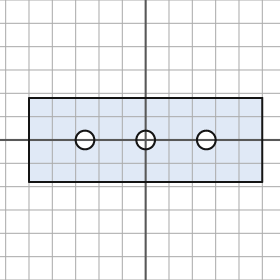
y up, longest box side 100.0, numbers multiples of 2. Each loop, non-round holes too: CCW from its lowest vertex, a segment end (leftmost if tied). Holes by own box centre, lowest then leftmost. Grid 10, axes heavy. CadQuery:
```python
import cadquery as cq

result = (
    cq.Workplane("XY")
    .moveTo(-50.0, -18.0)
    .lineTo(50.0, -18.0)
    .lineTo(50.0, 18.0)
    .lineTo(-50.0, 18.0)
    .close()
    .moveTo(-26.0, 0.0)
    .circle(4.0)
    .moveTo(0.0, 0.0)
    .circle(4.0)
    .moveTo(26.0, 0.0)
    .circle(4.0)
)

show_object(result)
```